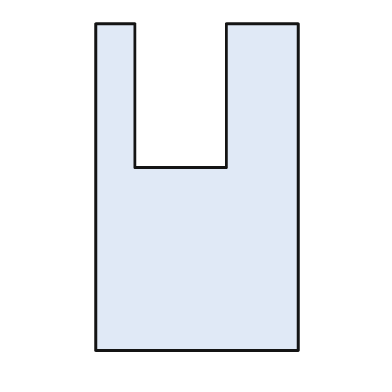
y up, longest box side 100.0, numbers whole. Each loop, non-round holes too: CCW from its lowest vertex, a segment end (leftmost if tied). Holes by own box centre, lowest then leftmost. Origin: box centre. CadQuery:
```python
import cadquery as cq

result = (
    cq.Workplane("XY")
    .moveTo(-31.0, -50.0)
    .lineTo(31.0, -50.0)
    .lineTo(31.0, 50.0)
    .lineTo(9.0, 50.0)
    .lineTo(9.0, 6.0)
    .lineTo(-19.0, 6.0)
    .lineTo(-19.0, 50.0)
    .lineTo(-31.0, 50.0)
    .close()
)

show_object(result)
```